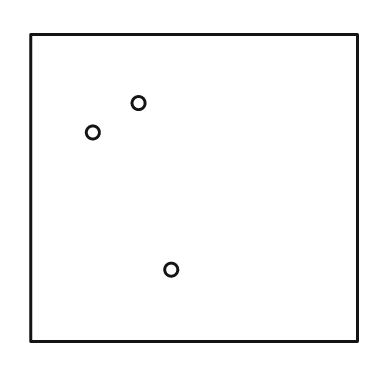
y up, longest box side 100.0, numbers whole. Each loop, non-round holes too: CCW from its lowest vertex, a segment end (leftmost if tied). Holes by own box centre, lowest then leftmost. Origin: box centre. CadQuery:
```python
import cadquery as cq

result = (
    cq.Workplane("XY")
    .moveTo(-50.0, -47.0)
    .lineTo(50.0, -47.0)
    .lineTo(50.0, 47.0)
    .lineTo(-50.0, 47.0)
    .close()
    .moveTo(-7.0, -25.0)
    .circle(2.0)
    .moveTo(-31.0, 17.0)
    .circle(2.0)
    .moveTo(-17.0, 26.0)
    .circle(2.0)
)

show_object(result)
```